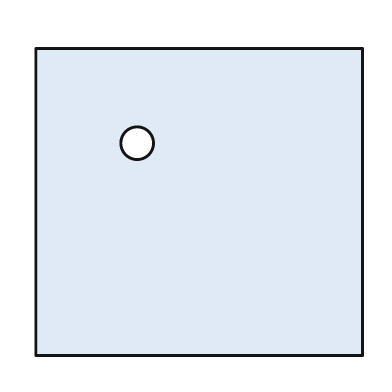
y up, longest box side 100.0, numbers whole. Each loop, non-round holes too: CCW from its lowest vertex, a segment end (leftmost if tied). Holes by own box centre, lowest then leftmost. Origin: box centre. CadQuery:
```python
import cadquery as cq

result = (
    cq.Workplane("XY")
    .moveTo(-50.0, -47.0)
    .lineTo(50.0, -47.0)
    .lineTo(50.0, 47.0)
    .lineTo(-50.0, 47.0)
    .close()
    .moveTo(-19.0, 18.0)
    .circle(5.0)
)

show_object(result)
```